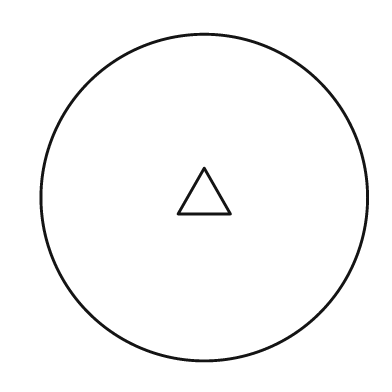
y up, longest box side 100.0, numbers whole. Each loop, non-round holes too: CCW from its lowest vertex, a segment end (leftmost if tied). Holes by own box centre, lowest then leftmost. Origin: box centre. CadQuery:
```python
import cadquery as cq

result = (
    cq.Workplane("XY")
    .moveTo(0.0, 0.0)
    .circle(50.0)
    .moveTo(-8.0, -5.0)
    .lineTo(8.0, -5.0)
    .lineTo(0.0, 9.0)
    .close()
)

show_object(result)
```